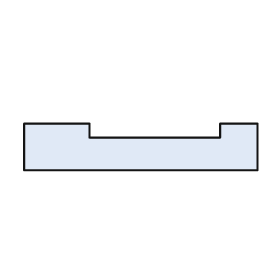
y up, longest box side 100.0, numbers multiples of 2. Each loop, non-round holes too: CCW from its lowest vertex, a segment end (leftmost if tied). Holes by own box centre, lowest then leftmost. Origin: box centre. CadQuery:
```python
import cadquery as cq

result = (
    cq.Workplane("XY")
    .moveTo(-50.0, -10.0)
    .lineTo(50.0, -10.0)
    .lineTo(50.0, 10.0)
    .lineTo(34.0, 10.0)
    .lineTo(34.0, 4.0)
    .lineTo(-22.0, 4.0)
    .lineTo(-22.0, 10.0)
    .lineTo(-50.0, 10.0)
    .close()
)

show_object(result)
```